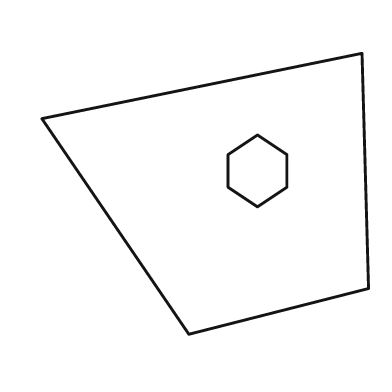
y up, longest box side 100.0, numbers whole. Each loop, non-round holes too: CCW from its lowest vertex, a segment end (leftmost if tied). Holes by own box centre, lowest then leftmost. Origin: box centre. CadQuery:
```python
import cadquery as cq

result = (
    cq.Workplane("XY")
    .moveTo(-5.0, -43.0)
    .lineTo(50.0, -29.0)
    .lineTo(48.0, 43.0)
    .lineTo(-50.0, 23.0)
    .close()
    .moveTo(16.0, -4.0)
    .lineTo(25.0, 2.0)
    .lineTo(25.0, 12.0)
    .lineTo(16.0, 18.0)
    .lineTo(7.0, 12.0)
    .lineTo(7.0, 2.0)
    .close()
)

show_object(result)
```